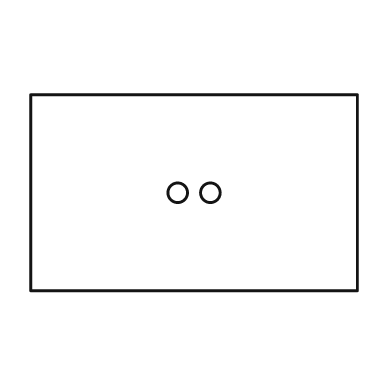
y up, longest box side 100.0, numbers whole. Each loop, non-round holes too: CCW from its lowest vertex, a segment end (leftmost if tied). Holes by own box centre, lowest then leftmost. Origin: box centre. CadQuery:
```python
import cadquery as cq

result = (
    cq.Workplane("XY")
    .moveTo(-50.0, -30.0)
    .lineTo(50.0, -30.0)
    .lineTo(50.0, 30.0)
    .lineTo(-50.0, 30.0)
    .close()
    .moveTo(-5.0, 0.0)
    .circle(3.0)
    .moveTo(5.0, 0.0)
    .circle(3.0)
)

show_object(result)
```